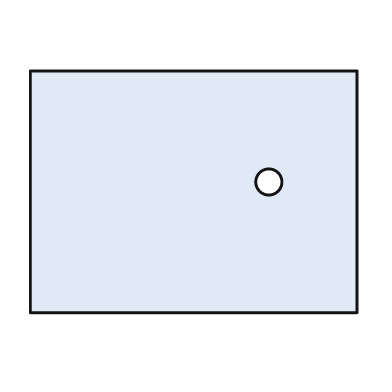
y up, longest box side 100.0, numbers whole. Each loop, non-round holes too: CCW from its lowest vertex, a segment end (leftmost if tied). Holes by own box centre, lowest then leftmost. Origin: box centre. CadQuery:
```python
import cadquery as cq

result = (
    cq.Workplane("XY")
    .moveTo(-50.0, -37.0)
    .lineTo(50.0, -37.0)
    .lineTo(50.0, 37.0)
    .lineTo(-50.0, 37.0)
    .close()
    .moveTo(23.0, 3.0)
    .circle(4.0)
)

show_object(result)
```